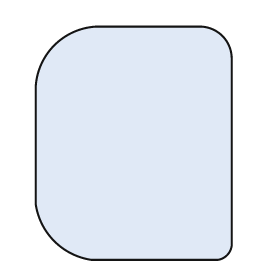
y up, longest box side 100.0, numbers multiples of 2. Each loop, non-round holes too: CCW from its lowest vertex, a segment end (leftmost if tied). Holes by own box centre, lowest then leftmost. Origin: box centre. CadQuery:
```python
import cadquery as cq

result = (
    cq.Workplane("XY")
    .moveTo(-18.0, -50.0)
    .lineTo(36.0, -50.0)
    .threePointArc((40.0, -48.0), (42.0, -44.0))
    .lineTo(42.0, 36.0)
    .threePointArc((38.0, 46.0), (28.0, 50.0))
    .lineTo(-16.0, 50.0)
    .threePointArc((-34.0, 42.0), (-42.0, 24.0))
    .lineTo(-42.0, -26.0)
    .threePointArc((-34.0, -42.0), (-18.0, -50.0))
    .close()
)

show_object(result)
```